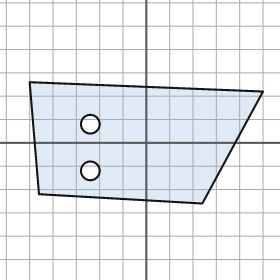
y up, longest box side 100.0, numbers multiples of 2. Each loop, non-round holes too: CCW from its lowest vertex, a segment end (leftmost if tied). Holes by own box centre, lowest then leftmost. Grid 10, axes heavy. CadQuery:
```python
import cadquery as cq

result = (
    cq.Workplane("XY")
    .moveTo(24.0, -26.0)
    .lineTo(50.0, 22.0)
    .lineTo(-50.0, 26.0)
    .lineTo(-46.0, -22.0)
    .close()
    .moveTo(-24.0, -12.0)
    .circle(4.0)
    .moveTo(-24.0, 8.0)
    .circle(4.0)
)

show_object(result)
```